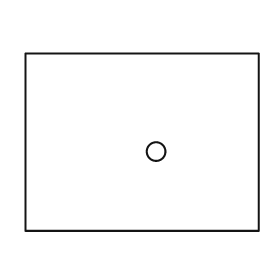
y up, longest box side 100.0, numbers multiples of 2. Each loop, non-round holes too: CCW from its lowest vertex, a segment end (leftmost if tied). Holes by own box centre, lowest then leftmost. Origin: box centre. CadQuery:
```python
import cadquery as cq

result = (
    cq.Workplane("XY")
    .moveTo(-50.0, -38.0)
    .lineTo(50.0, -38.0)
    .lineTo(50.0, 38.0)
    .lineTo(-50.0, 38.0)
    .close()
    .moveTo(6.0, -4.0)
    .circle(4.0)
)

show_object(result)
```